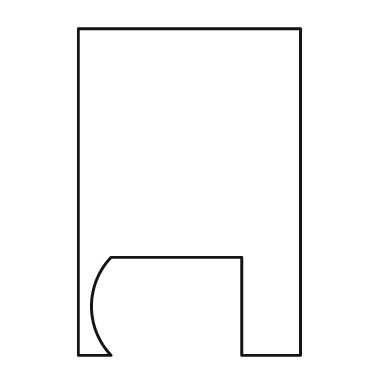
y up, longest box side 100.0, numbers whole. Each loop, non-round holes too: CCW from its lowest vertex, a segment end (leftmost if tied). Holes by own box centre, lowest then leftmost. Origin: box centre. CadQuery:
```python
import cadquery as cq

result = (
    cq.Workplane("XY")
    .moveTo(-34.0, -50.0)
    .lineTo(-24.0, -50.0)
    .threePointArc((-30.0, -35.0), (-24.0, -20.0))
    .lineTo(16.0, -20.0)
    .lineTo(16.0, -50.0)
    .lineTo(34.0, -50.0)
    .lineTo(34.0, 50.0)
    .lineTo(-34.0, 50.0)
    .close()
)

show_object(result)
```